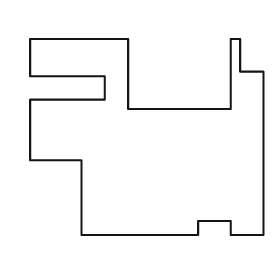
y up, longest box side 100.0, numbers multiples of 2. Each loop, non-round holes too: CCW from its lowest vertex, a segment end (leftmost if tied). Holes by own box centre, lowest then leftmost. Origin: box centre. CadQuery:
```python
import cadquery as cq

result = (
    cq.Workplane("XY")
    .moveTo(-28.0, -42.0)
    .lineTo(22.0, -42.0)
    .lineTo(22.0, -36.0)
    .lineTo(36.0, -36.0)
    .lineTo(36.0, -42.0)
    .lineTo(50.0, -42.0)
    .lineTo(50.0, 28.0)
    .lineTo(40.0, 28.0)
    .lineTo(40.0, 42.0)
    .lineTo(36.0, 42.0)
    .lineTo(36.0, 12.0)
    .lineTo(-8.0, 12.0)
    .lineTo(-8.0, 42.0)
    .lineTo(-50.0, 42.0)
    .lineTo(-50.0, 26.0)
    .lineTo(-18.0, 26.0)
    .lineTo(-18.0, 16.0)
    .lineTo(-50.0, 16.0)
    .lineTo(-50.0, -10.0)
    .lineTo(-28.0, -10.0)
    .close()
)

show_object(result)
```